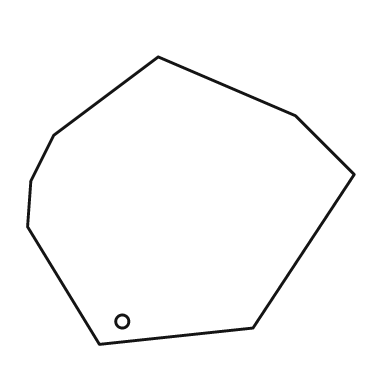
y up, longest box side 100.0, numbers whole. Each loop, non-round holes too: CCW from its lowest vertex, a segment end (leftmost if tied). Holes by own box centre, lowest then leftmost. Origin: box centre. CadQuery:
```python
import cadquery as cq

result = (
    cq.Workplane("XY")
    .moveTo(-28.0, -44.0)
    .lineTo(19.0, -39.0)
    .lineTo(50.0, 8.0)
    .lineTo(32.0, 26.0)
    .lineTo(-10.0, 44.0)
    .lineTo(-42.0, 20.0)
    .lineTo(-49.0, 6.0)
    .lineTo(-50.0, -8.0)
    .close()
    .moveTo(-21.0, -37.0)
    .circle(2.0)
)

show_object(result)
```